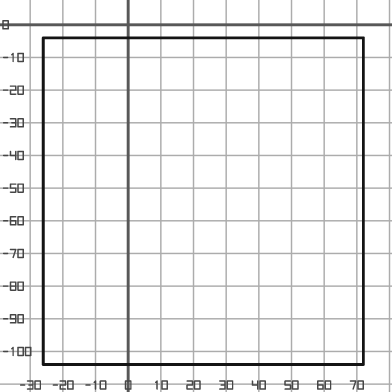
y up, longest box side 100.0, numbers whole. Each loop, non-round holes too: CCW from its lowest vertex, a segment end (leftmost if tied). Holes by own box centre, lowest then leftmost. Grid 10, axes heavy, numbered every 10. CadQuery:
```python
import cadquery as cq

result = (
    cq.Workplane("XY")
    .moveTo(-26.0, -104.0)
    .lineTo(72.0, -104.0)
    .lineTo(72.0, -4.0)
    .lineTo(-26.0, -4.0)
    .close()
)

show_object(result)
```